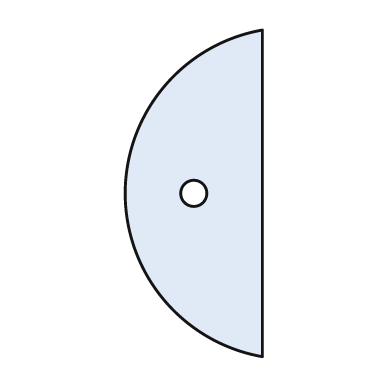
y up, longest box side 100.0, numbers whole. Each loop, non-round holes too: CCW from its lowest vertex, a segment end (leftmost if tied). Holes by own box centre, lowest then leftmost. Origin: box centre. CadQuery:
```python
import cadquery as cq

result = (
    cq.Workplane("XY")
    .moveTo(21.0, -50.0)
    .lineTo(21.0, 50.0)
    .threePointArc((-21.0, 0.0), (21.0, -50.0))
    .close()
    .moveTo(0.0, 0.0)
    .circle(4.0)
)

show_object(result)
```